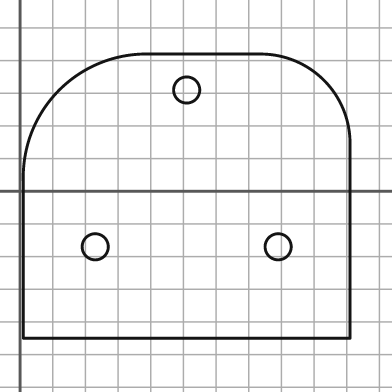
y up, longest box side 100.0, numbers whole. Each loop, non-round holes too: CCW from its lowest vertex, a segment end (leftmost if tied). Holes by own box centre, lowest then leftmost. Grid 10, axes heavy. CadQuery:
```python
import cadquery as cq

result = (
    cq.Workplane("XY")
    .moveTo(1.0, -45.0)
    .lineTo(101.0, -45.0)
    .lineTo(101.0, 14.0)
    .threePointArc((93.0, 34.0), (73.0, 42.0))
    .lineTo(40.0, 42.0)
    .threePointArc((12.0, 31.0), (1.0, 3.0))
    .close()
    .moveTo(23.0, -17.0)
    .circle(4.0)
    .moveTo(79.0, -17.0)
    .circle(4.0)
    .moveTo(51.0, 31.0)
    .circle(4.0)
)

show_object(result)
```